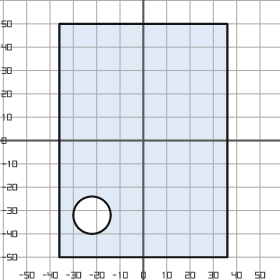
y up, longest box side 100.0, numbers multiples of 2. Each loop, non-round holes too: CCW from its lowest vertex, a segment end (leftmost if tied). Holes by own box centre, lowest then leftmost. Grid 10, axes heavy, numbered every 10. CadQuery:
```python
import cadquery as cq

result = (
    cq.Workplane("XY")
    .moveTo(-36.0, -50.0)
    .lineTo(36.0, -50.0)
    .lineTo(36.0, 50.0)
    .lineTo(-36.0, 50.0)
    .close()
    .moveTo(-22.0, -32.0)
    .circle(8.0)
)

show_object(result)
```